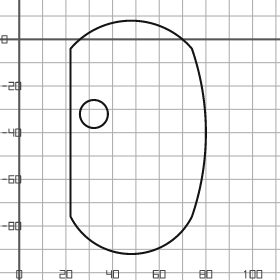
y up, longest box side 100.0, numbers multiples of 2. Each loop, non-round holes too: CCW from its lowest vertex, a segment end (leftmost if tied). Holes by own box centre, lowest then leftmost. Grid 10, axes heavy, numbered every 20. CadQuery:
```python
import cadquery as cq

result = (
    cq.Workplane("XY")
    .moveTo(22.0, -76.0)
    .threePointArc((48.0, -92.0), (74.0, -76.0))
    .threePointArc((80.0, -40.0), (74.0, -4.0))
    .threePointArc((48.0, 8.0), (22.0, -4.0))
    .close()
    .moveTo(32.0, -32.0)
    .circle(6.0)
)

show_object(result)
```